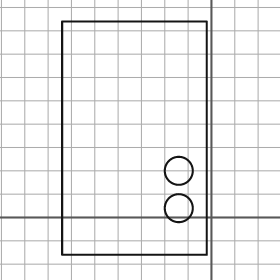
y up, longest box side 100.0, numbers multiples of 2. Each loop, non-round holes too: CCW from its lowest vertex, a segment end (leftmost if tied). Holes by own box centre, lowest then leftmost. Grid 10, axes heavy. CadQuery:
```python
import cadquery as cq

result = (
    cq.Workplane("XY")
    .moveTo(-64.0, -16.0)
    .lineTo(-2.0, -16.0)
    .lineTo(-2.0, 84.0)
    .lineTo(-64.0, 84.0)
    .close()
    .moveTo(-14.0, 4.0)
    .circle(6.0)
    .moveTo(-14.0, 20.0)
    .circle(6.0)
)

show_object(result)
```